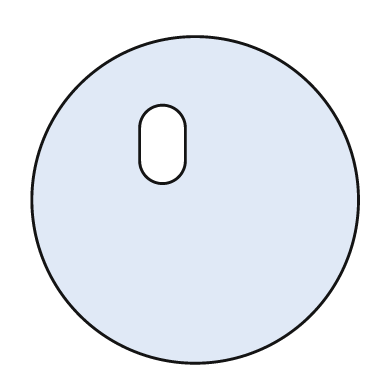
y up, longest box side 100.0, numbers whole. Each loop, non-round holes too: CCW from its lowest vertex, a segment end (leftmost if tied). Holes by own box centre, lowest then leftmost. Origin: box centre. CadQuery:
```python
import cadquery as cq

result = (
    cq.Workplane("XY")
    .moveTo(0.0, 0.0)
    .circle(50.0)
    .moveTo(-17.0, 12.0)
    .threePointArc((-10.0, 5.0), (-3.0, 12.0))
    .lineTo(-3.0, 22.0)
    .threePointArc((-10.0, 29.0), (-17.0, 22.0))
    .close()
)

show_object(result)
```